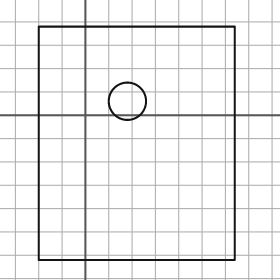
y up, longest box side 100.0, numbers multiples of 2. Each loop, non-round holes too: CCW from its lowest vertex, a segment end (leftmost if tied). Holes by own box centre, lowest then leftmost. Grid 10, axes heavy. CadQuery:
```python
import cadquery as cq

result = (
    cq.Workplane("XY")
    .moveTo(-20.0, -62.0)
    .lineTo(64.0, -62.0)
    .lineTo(64.0, 38.0)
    .lineTo(-20.0, 38.0)
    .close()
    .moveTo(18.0, 6.0)
    .circle(8.0)
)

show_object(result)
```